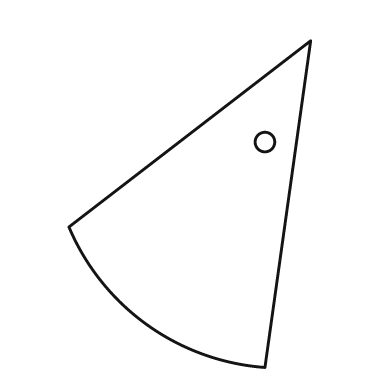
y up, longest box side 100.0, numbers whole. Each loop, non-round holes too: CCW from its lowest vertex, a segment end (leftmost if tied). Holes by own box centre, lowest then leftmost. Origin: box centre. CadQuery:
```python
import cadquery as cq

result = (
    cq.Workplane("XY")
    .moveTo(23.0, -50.0)
    .lineTo(37.0, 50.0)
    .lineTo(-37.0, -7.0)
    .threePointArc((-13.0, -37.0), (23.0, -50.0))
    .close()
    .moveTo(23.0, 19.0)
    .circle(3.0)
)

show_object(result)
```